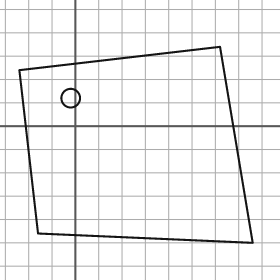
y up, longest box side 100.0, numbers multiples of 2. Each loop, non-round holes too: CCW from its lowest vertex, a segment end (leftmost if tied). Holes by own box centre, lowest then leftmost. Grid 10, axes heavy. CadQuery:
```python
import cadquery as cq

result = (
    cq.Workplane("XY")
    .moveTo(76.0, -50.0)
    .lineTo(62.0, 34.0)
    .lineTo(-24.0, 24.0)
    .lineTo(-16.0, -46.0)
    .close()
    .moveTo(-2.0, 12.0)
    .circle(4.0)
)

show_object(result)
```